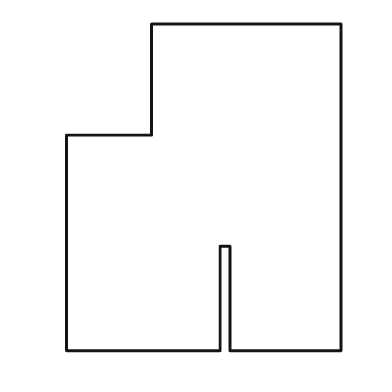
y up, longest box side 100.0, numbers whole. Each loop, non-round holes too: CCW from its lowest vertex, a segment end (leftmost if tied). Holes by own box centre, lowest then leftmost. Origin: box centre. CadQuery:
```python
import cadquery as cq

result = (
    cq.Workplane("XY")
    .moveTo(-42.0, -50.0)
    .lineTo(5.0, -50.0)
    .lineTo(5.0, -18.0)
    .lineTo(8.0, -18.0)
    .lineTo(8.0, -50.0)
    .lineTo(42.0, -50.0)
    .lineTo(42.0, 50.0)
    .lineTo(-16.0, 50.0)
    .lineTo(-16.0, 16.0)
    .lineTo(-42.0, 16.0)
    .close()
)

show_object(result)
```